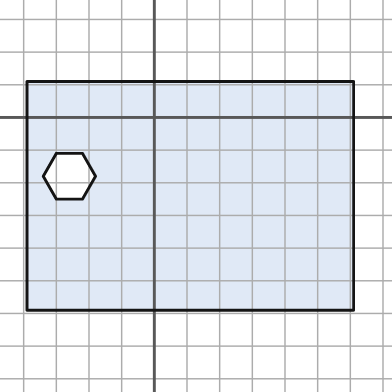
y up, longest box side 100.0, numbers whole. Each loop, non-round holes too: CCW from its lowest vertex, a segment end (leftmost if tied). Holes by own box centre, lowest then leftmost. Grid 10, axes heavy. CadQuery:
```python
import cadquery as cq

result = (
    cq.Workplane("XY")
    .moveTo(-39.0, -59.0)
    .lineTo(61.0, -59.0)
    .lineTo(61.0, 11.0)
    .lineTo(-39.0, 11.0)
    .close()
    .moveTo(-30.0, -25.0)
    .lineTo(-22.0, -25.0)
    .lineTo(-18.0, -18.0)
    .lineTo(-22.0, -11.0)
    .lineTo(-30.0, -11.0)
    .lineTo(-34.0, -18.0)
    .close()
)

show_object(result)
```